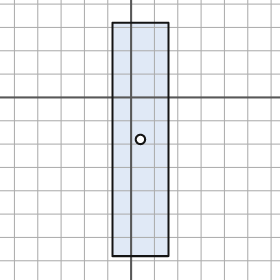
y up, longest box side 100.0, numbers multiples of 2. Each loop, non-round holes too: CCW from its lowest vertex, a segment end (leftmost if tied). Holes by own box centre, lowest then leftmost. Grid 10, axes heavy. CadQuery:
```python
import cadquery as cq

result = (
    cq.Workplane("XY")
    .moveTo(-8.0, -68.0)
    .lineTo(16.0, -68.0)
    .lineTo(16.0, 32.0)
    .lineTo(-8.0, 32.0)
    .close()
    .moveTo(4.0, -18.0)
    .circle(2.0)
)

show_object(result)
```